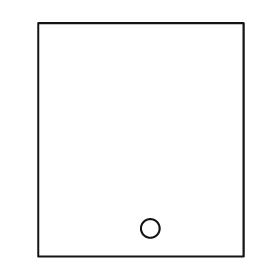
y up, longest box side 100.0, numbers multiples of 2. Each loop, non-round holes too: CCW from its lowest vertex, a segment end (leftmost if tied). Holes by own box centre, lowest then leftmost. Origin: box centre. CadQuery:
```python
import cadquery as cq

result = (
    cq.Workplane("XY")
    .moveTo(-44.0, -50.0)
    .lineTo(44.0, -50.0)
    .lineTo(44.0, 50.0)
    .lineTo(-44.0, 50.0)
    .close()
    .moveTo(4.0, -38.0)
    .circle(4.0)
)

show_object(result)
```